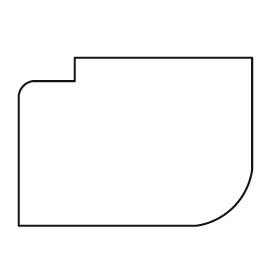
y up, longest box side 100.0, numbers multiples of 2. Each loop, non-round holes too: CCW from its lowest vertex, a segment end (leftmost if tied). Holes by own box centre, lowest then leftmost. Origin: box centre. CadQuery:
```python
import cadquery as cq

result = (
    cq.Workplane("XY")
    .moveTo(-50.0, -36.0)
    .lineTo(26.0, -36.0)
    .threePointArc((42.0, -28.0), (50.0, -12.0))
    .lineTo(50.0, 36.0)
    .lineTo(-26.0, 36.0)
    .lineTo(-26.0, 26.0)
    .lineTo(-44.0, 26.0)
    .threePointArc((-48.0, 24.0), (-50.0, 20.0))
    .close()
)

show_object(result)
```